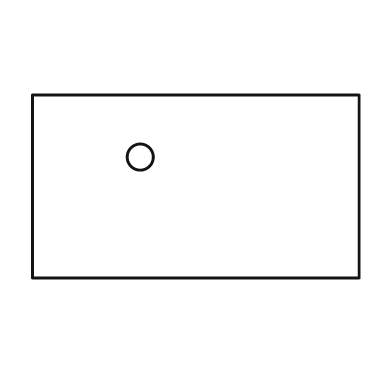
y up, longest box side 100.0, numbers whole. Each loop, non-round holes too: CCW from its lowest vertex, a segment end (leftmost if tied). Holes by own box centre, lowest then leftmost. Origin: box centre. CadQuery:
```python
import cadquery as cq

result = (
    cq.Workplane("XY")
    .moveTo(-50.0, -28.0)
    .lineTo(50.0, -28.0)
    .lineTo(50.0, 28.0)
    .lineTo(-50.0, 28.0)
    .close()
    .moveTo(-17.0, 9.0)
    .circle(4.0)
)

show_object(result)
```